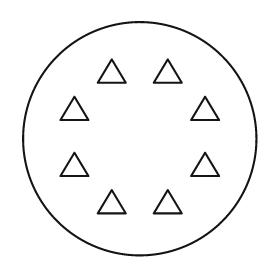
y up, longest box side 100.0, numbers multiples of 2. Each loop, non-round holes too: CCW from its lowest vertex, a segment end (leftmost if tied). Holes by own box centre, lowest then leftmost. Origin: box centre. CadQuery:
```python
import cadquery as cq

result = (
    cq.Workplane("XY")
    .moveTo(0.0, 0.0)
    .circle(50.0)
    .moveTo(-18.0, -32.0)
    .lineTo(-6.0, -32.0)
    .lineTo(-12.0, -22.0)
    .close()
    .moveTo(6.0, -32.0)
    .lineTo(18.0, -32.0)
    .lineTo(12.0, -22.0)
    .close()
    .moveTo(-34.0, -16.0)
    .lineTo(-22.0, -16.0)
    .lineTo(-28.0, -6.0)
    .close()
    .moveTo(22.0, -16.0)
    .lineTo(34.0, -16.0)
    .lineTo(28.0, -6.0)
    .close()
    .moveTo(-34.0, 8.0)
    .lineTo(-22.0, 8.0)
    .lineTo(-28.0, 18.0)
    .close()
    .moveTo(22.0, 8.0)
    .lineTo(34.0, 8.0)
    .lineTo(28.0, 18.0)
    .close()
    .moveTo(-18.0, 24.0)
    .lineTo(-6.0, 24.0)
    .lineTo(-12.0, 34.0)
    .close()
    .moveTo(6.0, 24.0)
    .lineTo(18.0, 24.0)
    .lineTo(12.0, 34.0)
    .close()
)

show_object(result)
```